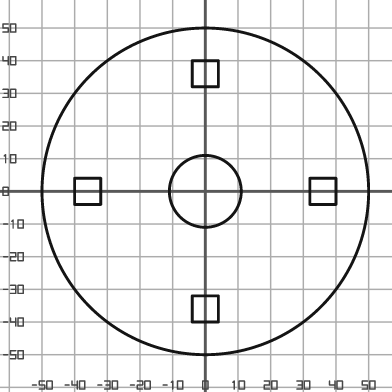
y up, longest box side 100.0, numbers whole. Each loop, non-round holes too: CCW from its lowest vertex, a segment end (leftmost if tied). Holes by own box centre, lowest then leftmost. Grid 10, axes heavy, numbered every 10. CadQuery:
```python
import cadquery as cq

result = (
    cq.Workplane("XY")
    .moveTo(0.0, 0.0)
    .circle(50.0)
    .moveTo(-4.0, -40.0)
    .lineTo(4.0, -40.0)
    .lineTo(4.0, -32.0)
    .lineTo(-4.0, -32.0)
    .close()
    .moveTo(-40.0, -4.0)
    .lineTo(-32.0, -4.0)
    .lineTo(-32.0, 4.0)
    .lineTo(-40.0, 4.0)
    .close()
    .moveTo(0.0, 0.0)
    .circle(11.0)
    .moveTo(32.0, -4.0)
    .lineTo(40.0, -4.0)
    .lineTo(40.0, 4.0)
    .lineTo(32.0, 4.0)
    .close()
    .moveTo(-4.0, 32.0)
    .lineTo(4.0, 32.0)
    .lineTo(4.0, 40.0)
    .lineTo(-4.0, 40.0)
    .close()
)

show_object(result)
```